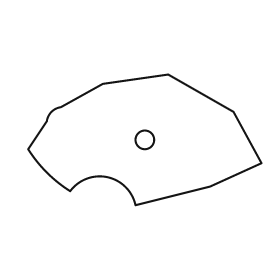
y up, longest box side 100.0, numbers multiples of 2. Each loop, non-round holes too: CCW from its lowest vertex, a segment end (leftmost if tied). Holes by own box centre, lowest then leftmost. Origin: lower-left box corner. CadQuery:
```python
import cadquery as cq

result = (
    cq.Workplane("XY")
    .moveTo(46.0, 0.0)
    .lineTo(78.0, 8.0)
    .lineTo(100.0, 18.0)
    .lineTo(88.0, 40.0)
    .lineTo(60.0, 56.0)
    .lineTo(32.0, 52.0)
    .lineTo(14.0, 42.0)
    .threePointArc((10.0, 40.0), (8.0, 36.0))
    .lineTo(0.0, 24.0)
    .threePointArc((8.0, 14.0), (18.0, 6.0))
    .threePointArc((34.0, 12.0), (46.0, 0.0))
    .close()
    .moveTo(50.0, 28.0)
    .circle(4.0)
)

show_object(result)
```